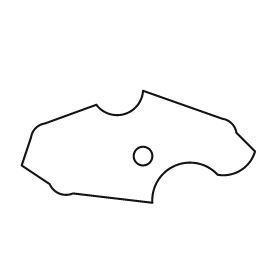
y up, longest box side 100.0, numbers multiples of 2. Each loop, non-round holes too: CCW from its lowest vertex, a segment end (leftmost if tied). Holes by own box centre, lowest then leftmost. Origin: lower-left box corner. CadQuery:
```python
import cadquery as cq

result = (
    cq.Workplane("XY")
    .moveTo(56.0, 0.0)
    .threePointArc((66.0, 16.0), (84.0, 12.0))
    .threePointArc((94.0, 14.0), (100.0, 22.0))
    .lineTo(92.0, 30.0)
    .threePointArc((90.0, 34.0), (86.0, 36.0))
    .lineTo(52.0, 48.0)
    .threePointArc((44.0, 38.0), (32.0, 42.0))
    .lineTo(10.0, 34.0)
    .threePointArc((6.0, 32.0), (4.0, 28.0))
    .lineTo(0.0, 16.0)
    .lineTo(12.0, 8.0)
    .threePointArc((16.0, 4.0), (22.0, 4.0))
    .close()
    .moveTo(52.0, 20.0)
    .circle(4.0)
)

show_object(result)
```